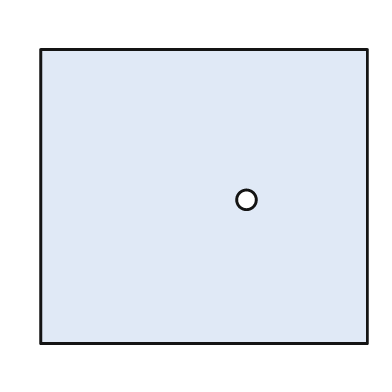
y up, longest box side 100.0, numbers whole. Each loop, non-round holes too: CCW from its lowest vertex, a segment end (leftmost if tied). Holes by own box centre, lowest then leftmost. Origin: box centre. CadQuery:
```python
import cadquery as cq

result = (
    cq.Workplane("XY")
    .moveTo(-50.0, -45.0)
    .lineTo(50.0, -45.0)
    .lineTo(50.0, 45.0)
    .lineTo(-50.0, 45.0)
    .close()
    .moveTo(13.0, -1.0)
    .circle(3.0)
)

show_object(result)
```